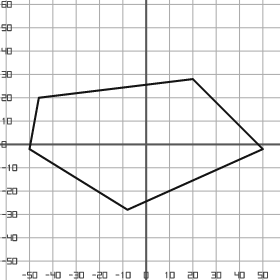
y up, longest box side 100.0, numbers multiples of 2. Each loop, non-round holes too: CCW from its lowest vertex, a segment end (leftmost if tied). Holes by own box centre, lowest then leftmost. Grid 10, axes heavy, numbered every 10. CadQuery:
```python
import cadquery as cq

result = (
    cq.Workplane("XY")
    .moveTo(-8.0, -28.0)
    .lineTo(50.0, -2.0)
    .lineTo(20.0, 28.0)
    .lineTo(-46.0, 20.0)
    .lineTo(-50.0, -2.0)
    .close()
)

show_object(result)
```